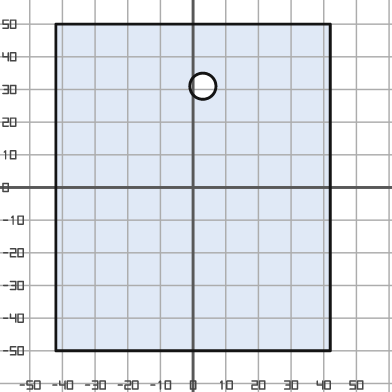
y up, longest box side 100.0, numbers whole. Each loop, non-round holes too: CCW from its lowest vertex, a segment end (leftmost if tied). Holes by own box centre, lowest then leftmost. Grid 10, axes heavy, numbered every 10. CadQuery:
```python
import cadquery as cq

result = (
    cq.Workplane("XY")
    .moveTo(-42.0, -50.0)
    .lineTo(42.0, -50.0)
    .lineTo(42.0, 50.0)
    .lineTo(-42.0, 50.0)
    .close()
    .moveTo(3.0, 31.0)
    .circle(4.0)
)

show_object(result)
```